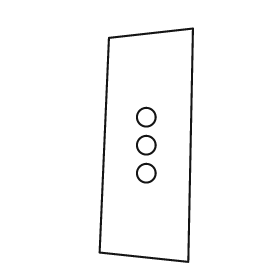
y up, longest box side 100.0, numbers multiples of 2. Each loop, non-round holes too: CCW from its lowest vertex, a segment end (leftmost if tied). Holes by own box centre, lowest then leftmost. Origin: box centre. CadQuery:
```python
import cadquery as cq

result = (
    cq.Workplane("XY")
    .moveTo(18.0, -50.0)
    .lineTo(20.0, 50.0)
    .lineTo(-16.0, 46.0)
    .lineTo(-20.0, -46.0)
    .close()
    .moveTo(0.0, -12.0)
    .circle(4.0)
    .moveTo(0.0, 0.0)
    .circle(4.0)
    .moveTo(0.0, 12.0)
    .circle(4.0)
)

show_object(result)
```